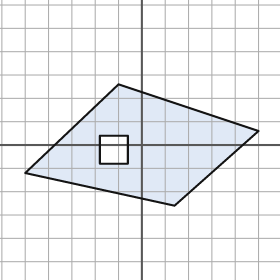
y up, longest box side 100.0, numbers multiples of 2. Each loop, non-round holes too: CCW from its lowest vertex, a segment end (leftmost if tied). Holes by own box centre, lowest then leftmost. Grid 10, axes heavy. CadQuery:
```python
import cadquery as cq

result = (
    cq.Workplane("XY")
    .moveTo(14.0, -26.0)
    .lineTo(50.0, 6.0)
    .lineTo(-10.0, 26.0)
    .lineTo(-50.0, -12.0)
    .close()
    .moveTo(-18.0, -8.0)
    .lineTo(-6.0, -8.0)
    .lineTo(-6.0, 4.0)
    .lineTo(-18.0, 4.0)
    .close()
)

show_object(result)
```